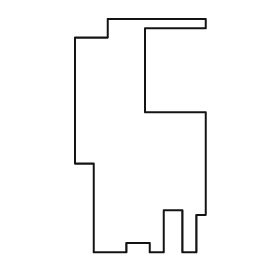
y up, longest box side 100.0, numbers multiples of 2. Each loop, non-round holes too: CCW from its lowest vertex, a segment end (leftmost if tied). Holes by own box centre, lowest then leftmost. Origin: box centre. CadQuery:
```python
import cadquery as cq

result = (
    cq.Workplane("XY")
    .moveTo(-20.0, -50.0)
    .lineTo(-6.0, -50.0)
    .lineTo(-6.0, -46.0)
    .lineTo(4.0, -46.0)
    .lineTo(4.0, -50.0)
    .lineTo(10.0, -50.0)
    .lineTo(10.0, -32.0)
    .lineTo(18.0, -32.0)
    .lineTo(18.0, -50.0)
    .lineTo(24.0, -50.0)
    .lineTo(24.0, -34.0)
    .lineTo(28.0, -34.0)
    .lineTo(28.0, 10.0)
    .lineTo(2.0, 10.0)
    .lineTo(2.0, 46.0)
    .lineTo(28.0, 46.0)
    .lineTo(28.0, 50.0)
    .lineTo(-14.0, 50.0)
    .lineTo(-14.0, 42.0)
    .lineTo(-28.0, 42.0)
    .lineTo(-28.0, -12.0)
    .lineTo(-20.0, -12.0)
    .close()
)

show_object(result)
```